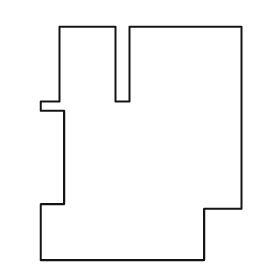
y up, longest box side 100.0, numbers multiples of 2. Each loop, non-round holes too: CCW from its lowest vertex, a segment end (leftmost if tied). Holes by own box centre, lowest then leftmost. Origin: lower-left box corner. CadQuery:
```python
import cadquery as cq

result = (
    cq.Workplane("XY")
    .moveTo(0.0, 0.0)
    .lineTo(70.0, 0.0)
    .lineTo(70.0, 22.0)
    .lineTo(86.0, 22.0)
    .lineTo(86.0, 100.0)
    .lineTo(38.0, 100.0)
    .lineTo(38.0, 68.0)
    .lineTo(32.0, 68.0)
    .lineTo(32.0, 100.0)
    .lineTo(8.0, 100.0)
    .lineTo(8.0, 68.0)
    .lineTo(0.0, 68.0)
    .lineTo(0.0, 64.0)
    .lineTo(10.0, 64.0)
    .lineTo(10.0, 24.0)
    .lineTo(0.0, 24.0)
    .close()
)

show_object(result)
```